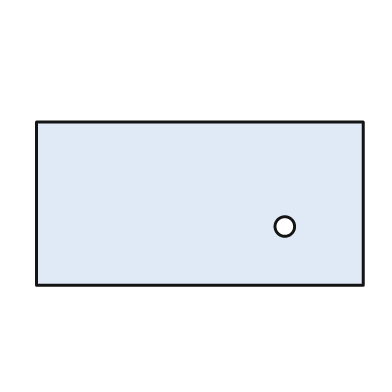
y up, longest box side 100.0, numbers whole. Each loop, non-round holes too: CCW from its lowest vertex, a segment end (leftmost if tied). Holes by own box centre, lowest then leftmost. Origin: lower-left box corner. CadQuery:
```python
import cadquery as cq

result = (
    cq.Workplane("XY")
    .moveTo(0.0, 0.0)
    .lineTo(100.0, 0.0)
    .lineTo(100.0, 50.0)
    .lineTo(0.0, 50.0)
    .close()
    .moveTo(76.0, 18.0)
    .circle(3.0)
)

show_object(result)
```